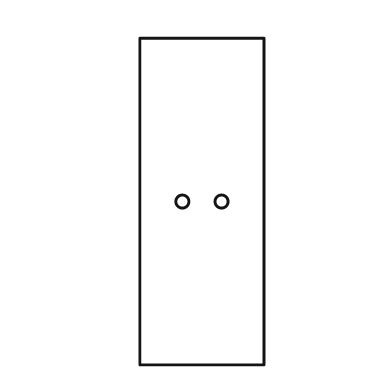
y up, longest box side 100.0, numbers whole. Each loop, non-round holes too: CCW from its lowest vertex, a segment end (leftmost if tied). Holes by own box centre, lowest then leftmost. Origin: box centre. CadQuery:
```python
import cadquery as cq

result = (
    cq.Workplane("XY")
    .moveTo(-19.0, -50.0)
    .lineTo(19.0, -50.0)
    .lineTo(19.0, 50.0)
    .lineTo(-19.0, 50.0)
    .close()
    .moveTo(-6.0, 0.0)
    .circle(2.0)
    .moveTo(6.0, 0.0)
    .circle(2.0)
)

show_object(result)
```